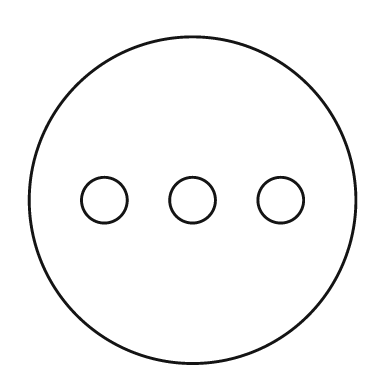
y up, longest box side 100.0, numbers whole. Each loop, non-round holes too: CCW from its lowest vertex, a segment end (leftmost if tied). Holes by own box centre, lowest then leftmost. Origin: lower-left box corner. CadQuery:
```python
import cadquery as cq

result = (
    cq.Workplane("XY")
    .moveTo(50.0, 50.0)
    .circle(50.0)
    .moveTo(23.0, 50.0)
    .circle(7.0)
    .moveTo(50.0, 50.0)
    .circle(7.0)
    .moveTo(77.0, 50.0)
    .circle(7.0)
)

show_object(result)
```